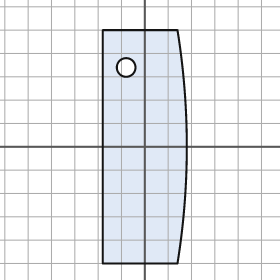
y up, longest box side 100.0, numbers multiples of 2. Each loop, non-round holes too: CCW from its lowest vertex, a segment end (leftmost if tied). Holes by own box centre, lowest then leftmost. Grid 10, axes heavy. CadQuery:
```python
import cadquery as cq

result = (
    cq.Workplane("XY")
    .moveTo(-18.0, -50.0)
    .lineTo(14.0, -50.0)
    .threePointArc((18.0, 0.0), (14.0, 50.0))
    .lineTo(-18.0, 50.0)
    .close()
    .moveTo(-8.0, 34.0)
    .circle(4.0)
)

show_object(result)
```